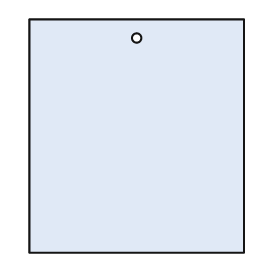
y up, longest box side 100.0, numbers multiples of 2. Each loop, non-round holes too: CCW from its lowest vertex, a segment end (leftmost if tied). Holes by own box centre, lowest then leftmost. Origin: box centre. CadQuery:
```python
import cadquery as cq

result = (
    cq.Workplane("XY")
    .moveTo(-46.0, -50.0)
    .lineTo(46.0, -50.0)
    .lineTo(46.0, 50.0)
    .lineTo(-46.0, 50.0)
    .close()
    .moveTo(0.0, 42.0)
    .circle(2.0)
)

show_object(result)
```